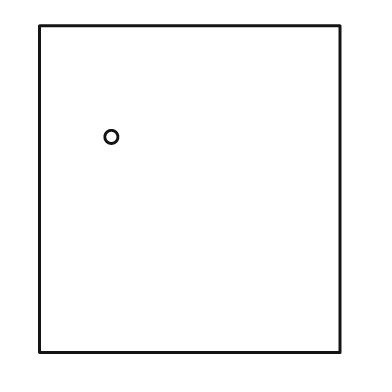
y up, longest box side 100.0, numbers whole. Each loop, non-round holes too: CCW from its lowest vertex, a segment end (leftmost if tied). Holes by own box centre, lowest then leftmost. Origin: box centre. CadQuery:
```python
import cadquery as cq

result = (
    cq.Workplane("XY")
    .moveTo(-46.0, -50.0)
    .lineTo(46.0, -50.0)
    .lineTo(46.0, 50.0)
    .lineTo(-46.0, 50.0)
    .close()
    .moveTo(-24.0, 16.0)
    .circle(2.0)
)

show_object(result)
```